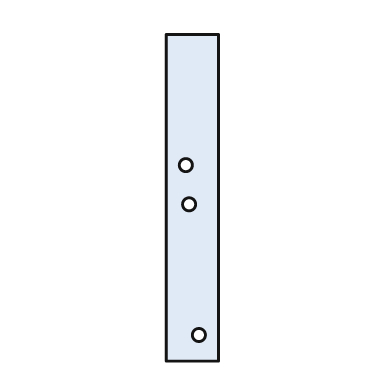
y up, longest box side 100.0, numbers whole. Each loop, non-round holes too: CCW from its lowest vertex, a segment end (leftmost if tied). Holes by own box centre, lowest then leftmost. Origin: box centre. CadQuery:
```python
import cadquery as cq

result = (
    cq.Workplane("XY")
    .moveTo(-8.0, -50.0)
    .lineTo(8.0, -50.0)
    .lineTo(8.0, 50.0)
    .lineTo(-8.0, 50.0)
    .close()
    .moveTo(2.0, -42.0)
    .circle(2.0)
    .moveTo(-1.0, -2.0)
    .circle(2.0)
    .moveTo(-2.0, 10.0)
    .circle(2.0)
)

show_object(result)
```